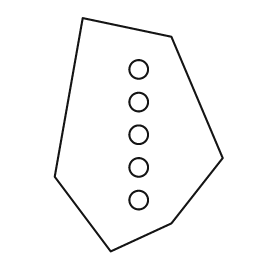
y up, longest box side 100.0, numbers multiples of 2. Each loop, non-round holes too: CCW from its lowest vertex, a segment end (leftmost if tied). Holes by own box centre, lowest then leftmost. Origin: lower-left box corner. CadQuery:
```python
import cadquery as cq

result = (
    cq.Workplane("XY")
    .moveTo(24.0, 0.0)
    .lineTo(50.0, 12.0)
    .lineTo(72.0, 40.0)
    .lineTo(50.0, 92.0)
    .lineTo(12.0, 100.0)
    .lineTo(0.0, 32.0)
    .close()
    .moveTo(36.0, 22.0)
    .circle(4.0)
    .moveTo(36.0, 36.0)
    .circle(4.0)
    .moveTo(36.0, 50.0)
    .circle(4.0)
    .moveTo(36.0, 64.0)
    .circle(4.0)
    .moveTo(36.0, 78.0)
    .circle(4.0)
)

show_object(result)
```